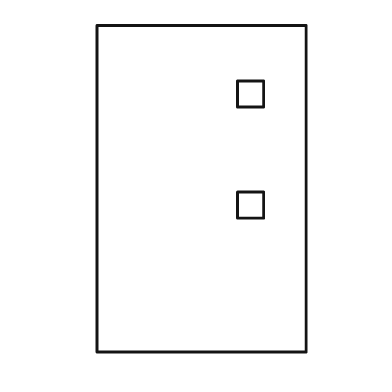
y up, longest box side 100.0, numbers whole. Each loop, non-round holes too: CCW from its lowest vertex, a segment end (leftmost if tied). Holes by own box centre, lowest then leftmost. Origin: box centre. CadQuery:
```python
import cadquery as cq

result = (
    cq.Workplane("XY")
    .moveTo(-32.0, -50.0)
    .lineTo(32.0, -50.0)
    .lineTo(32.0, 50.0)
    .lineTo(-32.0, 50.0)
    .close()
    .moveTo(11.0, -9.0)
    .lineTo(19.0, -9.0)
    .lineTo(19.0, -1.0)
    .lineTo(11.0, -1.0)
    .close()
    .moveTo(11.0, 25.0)
    .lineTo(19.0, 25.0)
    .lineTo(19.0, 33.0)
    .lineTo(11.0, 33.0)
    .close()
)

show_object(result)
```